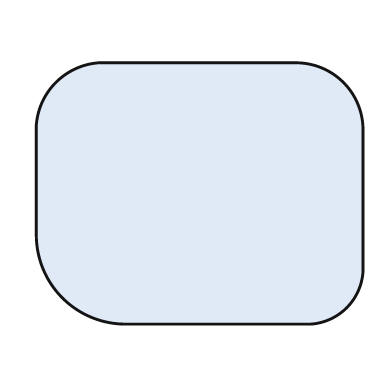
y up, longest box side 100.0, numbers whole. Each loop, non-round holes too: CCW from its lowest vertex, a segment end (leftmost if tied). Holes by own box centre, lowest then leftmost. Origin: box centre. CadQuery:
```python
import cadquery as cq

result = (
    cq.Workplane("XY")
    .moveTo(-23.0, -40.0)
    .lineTo(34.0, -40.0)
    .threePointArc((45.0, -35.0), (50.0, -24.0))
    .lineTo(50.0, 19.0)
    .threePointArc((44.0, 34.0), (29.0, 40.0))
    .lineTo(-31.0, 40.0)
    .threePointArc((-44.0, 34.0), (-50.0, 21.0))
    .lineTo(-50.0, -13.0)
    .threePointArc((-42.0, -32.0), (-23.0, -40.0))
    .close()
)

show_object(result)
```